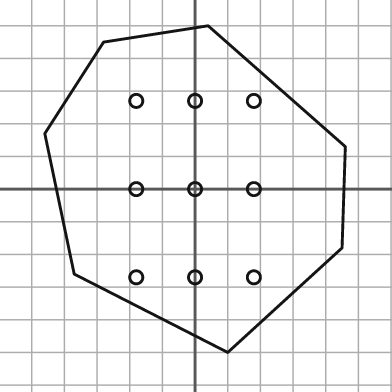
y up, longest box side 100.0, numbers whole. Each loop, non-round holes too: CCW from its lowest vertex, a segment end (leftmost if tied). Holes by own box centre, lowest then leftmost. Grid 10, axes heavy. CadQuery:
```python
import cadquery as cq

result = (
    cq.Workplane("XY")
    .moveTo(10.0, -50.0)
    .lineTo(45.0, -18.0)
    .lineTo(46.0, 13.0)
    .lineTo(4.0, 50.0)
    .lineTo(-28.0, 45.0)
    .lineTo(-46.0, 17.0)
    .lineTo(-37.0, -26.0)
    .close()
    .moveTo(-18.0, -27.0)
    .circle(2.0)
    .moveTo(0.0, -27.0)
    .circle(2.0)
    .moveTo(18.0, -27.0)
    .circle(2.0)
    .moveTo(-18.0, 0.0)
    .circle(2.0)
    .moveTo(0.0, 0.0)
    .circle(2.0)
    .moveTo(18.0, 0.0)
    .circle(2.0)
    .moveTo(-18.0, 27.0)
    .circle(2.0)
    .moveTo(0.0, 27.0)
    .circle(2.0)
    .moveTo(18.0, 27.0)
    .circle(2.0)
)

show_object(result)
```